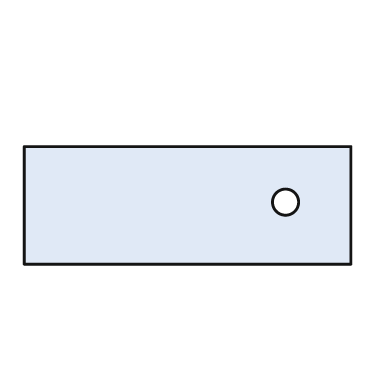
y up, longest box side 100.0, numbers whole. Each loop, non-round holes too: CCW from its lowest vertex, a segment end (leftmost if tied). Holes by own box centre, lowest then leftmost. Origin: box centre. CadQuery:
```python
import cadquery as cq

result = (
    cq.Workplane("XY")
    .moveTo(-50.0, -18.0)
    .lineTo(50.0, -18.0)
    .lineTo(50.0, 18.0)
    .lineTo(-50.0, 18.0)
    .close()
    .moveTo(30.0, 1.0)
    .circle(4.0)
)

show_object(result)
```